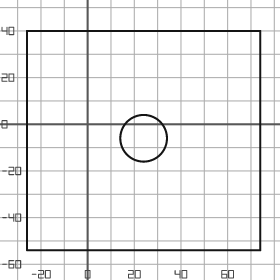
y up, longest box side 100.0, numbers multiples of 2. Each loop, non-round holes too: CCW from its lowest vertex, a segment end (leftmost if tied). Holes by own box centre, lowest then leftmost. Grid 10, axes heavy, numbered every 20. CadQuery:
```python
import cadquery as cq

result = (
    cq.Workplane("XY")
    .moveTo(-26.0, -54.0)
    .lineTo(74.0, -54.0)
    .lineTo(74.0, 40.0)
    .lineTo(-26.0, 40.0)
    .close()
    .moveTo(24.0, -6.0)
    .circle(10.0)
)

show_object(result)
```